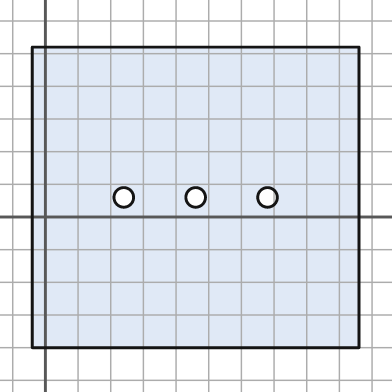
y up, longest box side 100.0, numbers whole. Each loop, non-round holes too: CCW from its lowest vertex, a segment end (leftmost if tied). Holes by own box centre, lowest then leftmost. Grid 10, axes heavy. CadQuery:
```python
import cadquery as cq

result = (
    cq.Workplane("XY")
    .moveTo(-4.0, -40.0)
    .lineTo(96.0, -40.0)
    .lineTo(96.0, 52.0)
    .lineTo(-4.0, 52.0)
    .close()
    .moveTo(24.0, 6.0)
    .circle(3.0)
    .moveTo(46.0, 6.0)
    .circle(3.0)
    .moveTo(68.0, 6.0)
    .circle(3.0)
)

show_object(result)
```